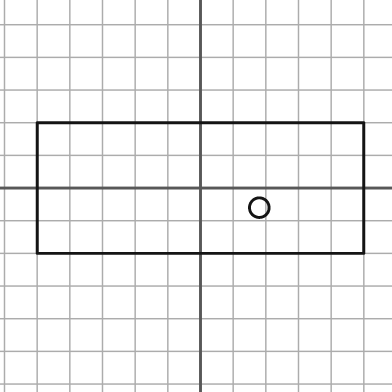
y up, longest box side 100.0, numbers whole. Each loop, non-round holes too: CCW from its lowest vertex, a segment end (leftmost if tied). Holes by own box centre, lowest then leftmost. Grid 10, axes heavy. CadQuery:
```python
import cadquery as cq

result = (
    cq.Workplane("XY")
    .moveTo(-50.0, -20.0)
    .lineTo(50.0, -20.0)
    .lineTo(50.0, 20.0)
    .lineTo(-50.0, 20.0)
    .close()
    .moveTo(18.0, -6.0)
    .circle(3.0)
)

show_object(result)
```